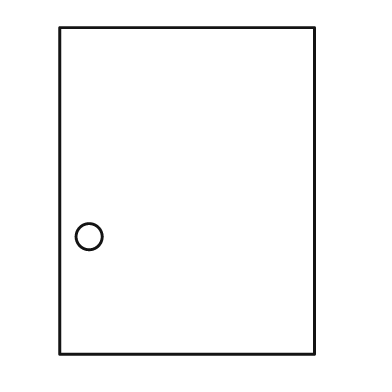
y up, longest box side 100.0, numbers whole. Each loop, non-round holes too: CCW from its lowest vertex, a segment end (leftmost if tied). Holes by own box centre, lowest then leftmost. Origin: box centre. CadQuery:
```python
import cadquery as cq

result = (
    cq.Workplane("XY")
    .moveTo(-39.0, -50.0)
    .lineTo(39.0, -50.0)
    .lineTo(39.0, 50.0)
    .lineTo(-39.0, 50.0)
    .close()
    .moveTo(-30.0, -14.0)
    .circle(4.0)
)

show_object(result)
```